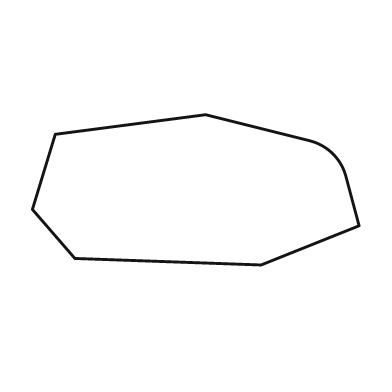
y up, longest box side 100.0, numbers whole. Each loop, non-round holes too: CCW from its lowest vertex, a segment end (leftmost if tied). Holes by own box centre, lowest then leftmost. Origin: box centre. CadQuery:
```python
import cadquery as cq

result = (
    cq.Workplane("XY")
    .moveTo(20.0, -23.0)
    .lineTo(50.0, -11.0)
    .lineTo(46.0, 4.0)
    .threePointArc((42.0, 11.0), (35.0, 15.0))
    .lineTo(3.0, 23.0)
    .lineTo(-43.0, 17.0)
    .lineTo(-50.0, -6.0)
    .lineTo(-37.0, -21.0)
    .close()
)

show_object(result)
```